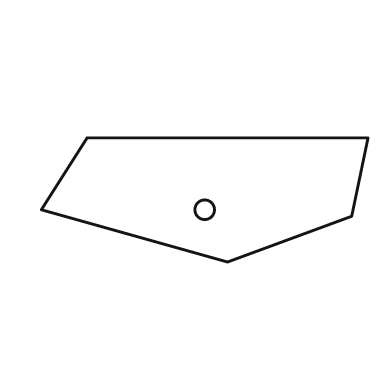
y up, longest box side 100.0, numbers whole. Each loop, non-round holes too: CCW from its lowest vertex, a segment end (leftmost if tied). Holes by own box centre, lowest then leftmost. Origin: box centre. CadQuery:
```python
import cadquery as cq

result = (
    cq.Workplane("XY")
    .moveTo(7.0, -19.0)
    .lineTo(45.0, -5.0)
    .lineTo(50.0, 19.0)
    .lineTo(-36.0, 19.0)
    .lineTo(-50.0, -3.0)
    .close()
    .moveTo(0.0, -3.0)
    .circle(3.0)
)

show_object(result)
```